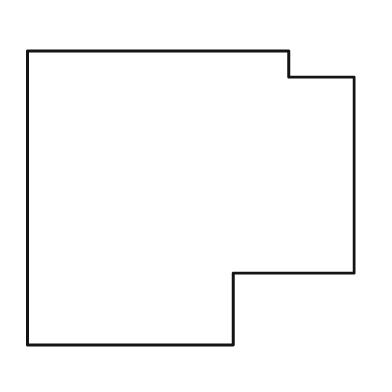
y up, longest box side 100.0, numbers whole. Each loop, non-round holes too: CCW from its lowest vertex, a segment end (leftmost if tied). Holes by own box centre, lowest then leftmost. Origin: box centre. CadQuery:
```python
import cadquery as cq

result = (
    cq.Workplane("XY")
    .moveTo(-50.0, -45.0)
    .lineTo(13.0, -45.0)
    .lineTo(13.0, -23.0)
    .lineTo(50.0, -23.0)
    .lineTo(50.0, 37.0)
    .lineTo(30.0, 37.0)
    .lineTo(30.0, 45.0)
    .lineTo(-50.0, 45.0)
    .close()
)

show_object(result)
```